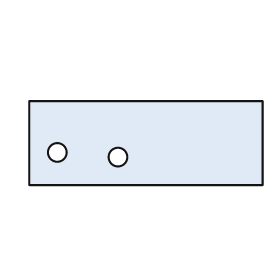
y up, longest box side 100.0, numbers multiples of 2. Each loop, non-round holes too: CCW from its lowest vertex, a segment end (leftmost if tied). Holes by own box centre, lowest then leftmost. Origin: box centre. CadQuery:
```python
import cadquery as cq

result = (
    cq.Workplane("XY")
    .moveTo(-50.0, -18.0)
    .lineTo(50.0, -18.0)
    .lineTo(50.0, 18.0)
    .lineTo(-50.0, 18.0)
    .close()
    .moveTo(-12.0, -6.0)
    .circle(4.0)
    .moveTo(-38.0, -4.0)
    .circle(4.0)
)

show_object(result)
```